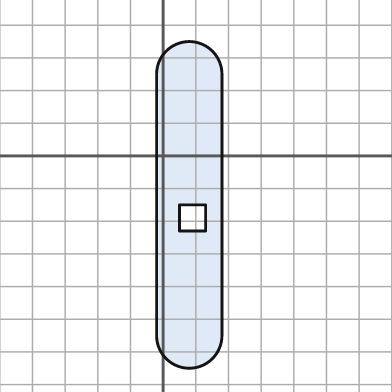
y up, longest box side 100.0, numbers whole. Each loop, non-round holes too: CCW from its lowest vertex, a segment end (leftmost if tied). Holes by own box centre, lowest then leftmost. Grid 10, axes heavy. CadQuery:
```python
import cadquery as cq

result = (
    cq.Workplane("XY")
    .moveTo(-2.0, -55.0)
    .threePointArc((8.0, -65.0), (18.0, -55.0))
    .lineTo(18.0, 25.0)
    .threePointArc((8.0, 35.0), (-2.0, 25.0))
    .close()
    .moveTo(5.0, -23.0)
    .lineTo(13.0, -23.0)
    .lineTo(13.0, -15.0)
    .lineTo(5.0, -15.0)
    .close()
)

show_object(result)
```